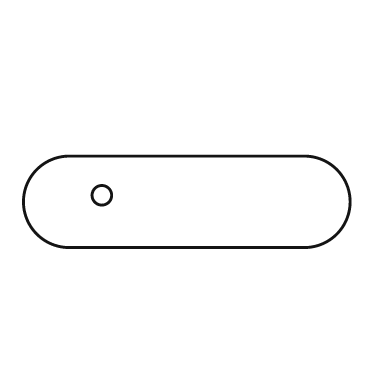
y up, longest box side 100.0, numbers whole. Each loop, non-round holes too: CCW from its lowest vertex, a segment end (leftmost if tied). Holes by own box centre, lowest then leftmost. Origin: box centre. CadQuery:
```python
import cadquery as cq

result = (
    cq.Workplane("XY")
    .moveTo(-36.0, -14.0)
    .lineTo(36.0, -14.0)
    .threePointArc((50.0, 0.0), (36.0, 14.0))
    .lineTo(-36.0, 14.0)
    .threePointArc((-50.0, 0.0), (-36.0, -14.0))
    .close()
    .moveTo(-26.0, 2.0)
    .circle(3.0)
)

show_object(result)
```